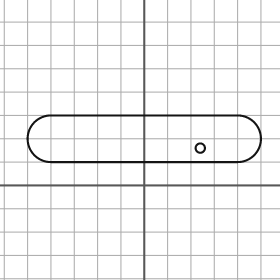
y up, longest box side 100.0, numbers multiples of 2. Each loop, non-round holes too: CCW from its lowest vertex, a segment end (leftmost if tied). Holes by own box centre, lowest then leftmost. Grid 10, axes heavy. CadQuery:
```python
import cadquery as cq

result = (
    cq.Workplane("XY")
    .moveTo(-40.0, 10.0)
    .lineTo(40.0, 10.0)
    .threePointArc((50.0, 20.0), (40.0, 30.0))
    .lineTo(-40.0, 30.0)
    .threePointArc((-50.0, 20.0), (-40.0, 10.0))
    .close()
    .moveTo(24.0, 16.0)
    .circle(2.0)
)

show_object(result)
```